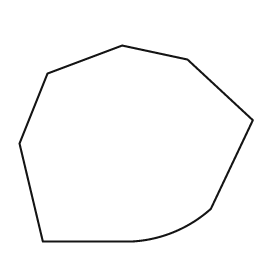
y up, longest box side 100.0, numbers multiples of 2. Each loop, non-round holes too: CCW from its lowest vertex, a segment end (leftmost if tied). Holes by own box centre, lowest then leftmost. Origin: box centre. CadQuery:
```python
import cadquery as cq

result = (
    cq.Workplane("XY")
    .moveTo(-40.0, -42.0)
    .lineTo(-2.0, -42.0)
    .threePointArc((16.0, -38.0), (32.0, -28.0))
    .lineTo(50.0, 10.0)
    .lineTo(22.0, 36.0)
    .lineTo(-6.0, 42.0)
    .lineTo(-38.0, 30.0)
    .lineTo(-50.0, 0.0)
    .close()
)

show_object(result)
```